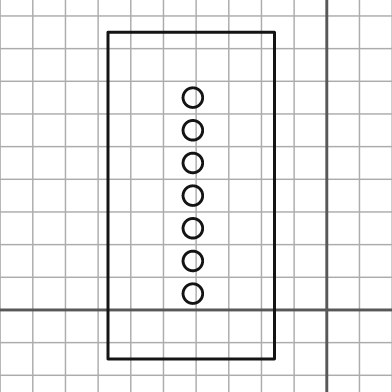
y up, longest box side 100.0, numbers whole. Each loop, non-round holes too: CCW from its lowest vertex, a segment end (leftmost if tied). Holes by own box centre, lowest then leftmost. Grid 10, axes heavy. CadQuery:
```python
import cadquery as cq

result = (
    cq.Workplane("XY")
    .moveTo(-67.0, -15.0)
    .lineTo(-16.0, -15.0)
    .lineTo(-16.0, 85.0)
    .lineTo(-67.0, 85.0)
    .close()
    .moveTo(-41.0, 5.0)
    .circle(3.0)
    .moveTo(-41.0, 15.0)
    .circle(3.0)
    .moveTo(-41.0, 25.0)
    .circle(3.0)
    .moveTo(-41.0, 35.0)
    .circle(3.0)
    .moveTo(-41.0, 45.0)
    .circle(3.0)
    .moveTo(-41.0, 55.0)
    .circle(3.0)
    .moveTo(-41.0, 65.0)
    .circle(3.0)
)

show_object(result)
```